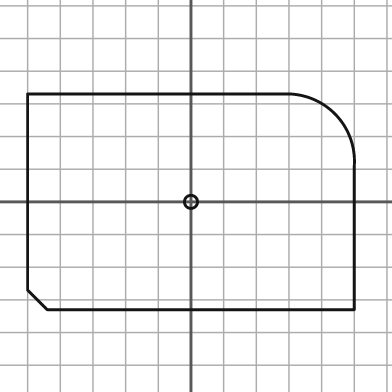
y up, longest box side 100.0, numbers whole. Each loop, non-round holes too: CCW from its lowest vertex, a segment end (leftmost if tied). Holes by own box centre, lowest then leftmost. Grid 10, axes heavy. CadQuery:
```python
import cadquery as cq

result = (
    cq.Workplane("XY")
    .moveTo(-44.0, -33.0)
    .lineTo(50.0, -33.0)
    .lineTo(50.0, 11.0)
    .threePointArc((44.0, 27.0), (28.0, 33.0))
    .lineTo(-50.0, 33.0)
    .lineTo(-50.0, -27.0)
    .close()
    .moveTo(0.0, 0.0)
    .circle(2.0)
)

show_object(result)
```